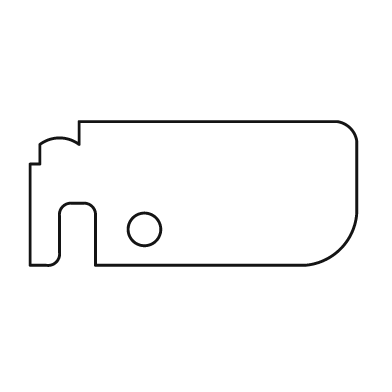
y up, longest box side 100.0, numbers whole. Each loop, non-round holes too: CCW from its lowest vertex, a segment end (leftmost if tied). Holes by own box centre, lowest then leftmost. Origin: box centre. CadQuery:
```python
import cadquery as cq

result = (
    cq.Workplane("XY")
    .moveTo(-50.0, -22.0)
    .lineTo(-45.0, -22.0)
    .threePointArc((-42.0, -21.0), (-41.0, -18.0))
    .lineTo(-41.0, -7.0)
    .threePointArc((-40.0, -4.0), (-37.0, -3.0))
    .lineTo(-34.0, -3.0)
    .threePointArc((-31.0, -4.0), (-30.0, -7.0))
    .lineTo(-30.0, -22.0)
    .lineTo(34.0, -22.0)
    .threePointArc((45.0, -17.0), (50.0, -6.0))
    .lineTo(50.0, 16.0)
    .threePointArc((48.0, 20.0), (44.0, 22.0))
    .lineTo(-35.0, 22.0)
    .lineTo(-35.0, 15.0)
    .threePointArc((-41.0, 17.0), (-47.0, 15.0))
    .lineTo(-47.0, 9.0)
    .lineTo(-50.0, 9.0)
    .close()
    .moveTo(-15.0, -11.0)
    .circle(5.0)
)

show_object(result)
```